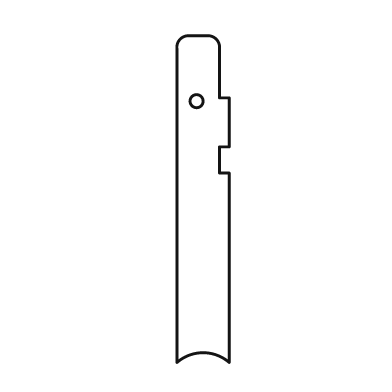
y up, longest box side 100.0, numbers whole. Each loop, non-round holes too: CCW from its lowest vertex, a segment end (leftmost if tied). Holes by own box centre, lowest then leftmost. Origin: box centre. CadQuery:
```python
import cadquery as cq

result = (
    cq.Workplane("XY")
    .moveTo(-8.0, -50.0)
    .threePointArc((0.0, -47.0), (8.0, -50.0))
    .lineTo(8.0, 8.0)
    .lineTo(5.0, 8.0)
    .lineTo(5.0, 16.0)
    .lineTo(8.0, 16.0)
    .lineTo(8.0, 31.0)
    .lineTo(5.0, 31.0)
    .lineTo(5.0, 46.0)
    .threePointArc((4.0, 49.0), (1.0, 50.0))
    .lineTo(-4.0, 50.0)
    .threePointArc((-7.0, 49.0), (-8.0, 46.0))
    .close()
    .moveTo(-2.0, 30.0)
    .circle(2.0)
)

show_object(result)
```